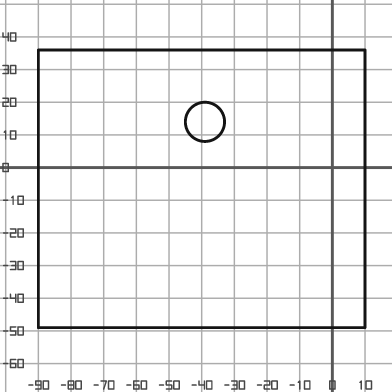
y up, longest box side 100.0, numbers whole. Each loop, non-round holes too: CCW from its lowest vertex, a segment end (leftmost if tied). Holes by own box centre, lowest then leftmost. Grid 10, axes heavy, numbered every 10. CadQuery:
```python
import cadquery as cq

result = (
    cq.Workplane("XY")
    .moveTo(-90.0, -49.0)
    .lineTo(10.0, -49.0)
    .lineTo(10.0, 36.0)
    .lineTo(-90.0, 36.0)
    .close()
    .moveTo(-39.0, 14.0)
    .circle(6.0)
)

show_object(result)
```